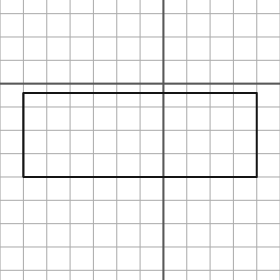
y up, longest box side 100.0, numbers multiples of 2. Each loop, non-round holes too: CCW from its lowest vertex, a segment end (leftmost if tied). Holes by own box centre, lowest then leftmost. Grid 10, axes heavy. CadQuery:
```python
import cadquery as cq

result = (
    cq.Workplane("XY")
    .moveTo(-60.0, -40.0)
    .lineTo(40.0, -40.0)
    .lineTo(40.0, -4.0)
    .lineTo(-60.0, -4.0)
    .close()
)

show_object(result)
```